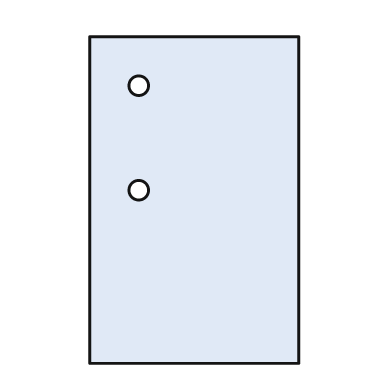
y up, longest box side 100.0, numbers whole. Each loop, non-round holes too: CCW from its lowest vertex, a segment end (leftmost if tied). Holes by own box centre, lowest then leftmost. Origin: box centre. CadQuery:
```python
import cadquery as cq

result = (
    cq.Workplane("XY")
    .moveTo(-32.0, -50.0)
    .lineTo(32.0, -50.0)
    .lineTo(32.0, 50.0)
    .lineTo(-32.0, 50.0)
    .close()
    .moveTo(-17.0, 3.0)
    .circle(3.0)
    .moveTo(-17.0, 35.0)
    .circle(3.0)
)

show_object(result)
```